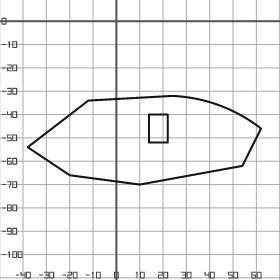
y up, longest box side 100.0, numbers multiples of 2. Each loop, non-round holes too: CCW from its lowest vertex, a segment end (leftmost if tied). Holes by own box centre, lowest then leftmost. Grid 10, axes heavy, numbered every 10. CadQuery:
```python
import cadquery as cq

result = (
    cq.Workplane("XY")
    .moveTo(10.0, -70.0)
    .lineTo(54.0, -62.0)
    .lineTo(62.0, -46.0)
    .threePointArc((44.0, -36.0), (24.0, -32.0))
    .lineTo(-12.0, -34.0)
    .lineTo(-38.0, -54.0)
    .lineTo(-20.0, -66.0)
    .close()
    .moveTo(14.0, -52.0)
    .lineTo(22.0, -52.0)
    .lineTo(22.0, -40.0)
    .lineTo(14.0, -40.0)
    .close()
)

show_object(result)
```